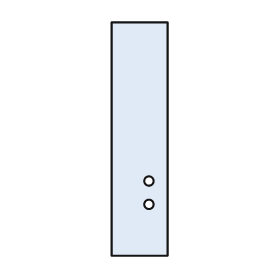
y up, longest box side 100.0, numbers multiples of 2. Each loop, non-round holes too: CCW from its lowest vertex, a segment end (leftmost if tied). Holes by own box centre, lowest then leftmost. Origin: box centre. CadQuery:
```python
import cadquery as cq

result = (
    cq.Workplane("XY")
    .moveTo(-12.0, -50.0)
    .lineTo(12.0, -50.0)
    .lineTo(12.0, 50.0)
    .lineTo(-12.0, 50.0)
    .close()
    .moveTo(4.0, -28.0)
    .circle(2.0)
    .moveTo(4.0, -18.0)
    .circle(2.0)
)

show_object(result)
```